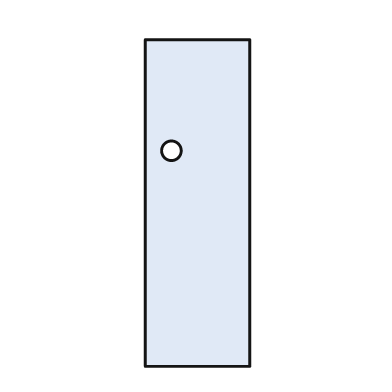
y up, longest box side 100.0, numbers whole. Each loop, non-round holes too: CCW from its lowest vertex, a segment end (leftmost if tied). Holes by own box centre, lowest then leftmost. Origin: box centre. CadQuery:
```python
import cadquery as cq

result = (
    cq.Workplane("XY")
    .moveTo(-16.0, -50.0)
    .lineTo(16.0, -50.0)
    .lineTo(16.0, 50.0)
    .lineTo(-16.0, 50.0)
    .close()
    .moveTo(-8.0, 16.0)
    .circle(3.0)
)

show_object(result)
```